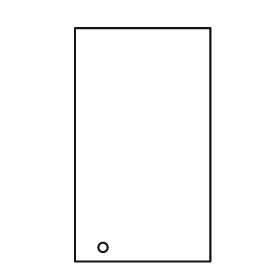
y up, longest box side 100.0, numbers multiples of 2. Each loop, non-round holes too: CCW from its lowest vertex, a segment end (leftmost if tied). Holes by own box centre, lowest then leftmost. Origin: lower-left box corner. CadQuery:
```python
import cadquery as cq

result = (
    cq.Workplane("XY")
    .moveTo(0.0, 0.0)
    .lineTo(58.0, 0.0)
    .lineTo(58.0, 100.0)
    .lineTo(0.0, 100.0)
    .close()
    .moveTo(12.0, 6.0)
    .circle(2.0)
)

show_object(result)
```